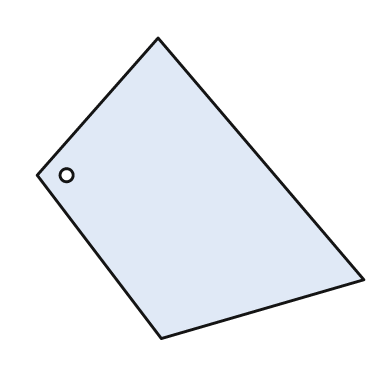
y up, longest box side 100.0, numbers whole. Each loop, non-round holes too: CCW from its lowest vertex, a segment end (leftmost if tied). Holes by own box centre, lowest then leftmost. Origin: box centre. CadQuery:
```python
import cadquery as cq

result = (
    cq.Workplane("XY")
    .moveTo(-12.0, -46.0)
    .lineTo(50.0, -28.0)
    .lineTo(-13.0, 46.0)
    .lineTo(-50.0, 4.0)
    .close()
    .moveTo(-41.0, 4.0)
    .circle(2.0)
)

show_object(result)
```